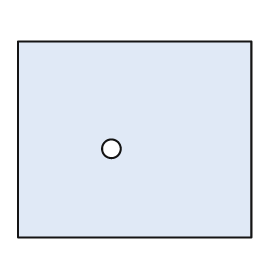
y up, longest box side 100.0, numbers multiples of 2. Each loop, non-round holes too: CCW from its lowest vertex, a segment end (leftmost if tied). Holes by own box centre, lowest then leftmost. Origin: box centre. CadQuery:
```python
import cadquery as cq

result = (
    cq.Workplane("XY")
    .moveTo(-50.0, -42.0)
    .lineTo(50.0, -42.0)
    .lineTo(50.0, 42.0)
    .lineTo(-50.0, 42.0)
    .close()
    .moveTo(-10.0, -4.0)
    .circle(4.0)
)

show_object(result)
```